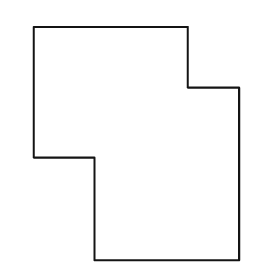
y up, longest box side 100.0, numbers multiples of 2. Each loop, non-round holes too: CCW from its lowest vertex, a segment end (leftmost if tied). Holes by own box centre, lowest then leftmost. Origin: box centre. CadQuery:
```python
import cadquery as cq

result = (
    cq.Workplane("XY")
    .moveTo(-18.0, -50.0)
    .lineTo(44.0, -50.0)
    .lineTo(44.0, 24.0)
    .lineTo(22.0, 24.0)
    .lineTo(22.0, 50.0)
    .lineTo(-44.0, 50.0)
    .lineTo(-44.0, -6.0)
    .lineTo(-18.0, -6.0)
    .close()
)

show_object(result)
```